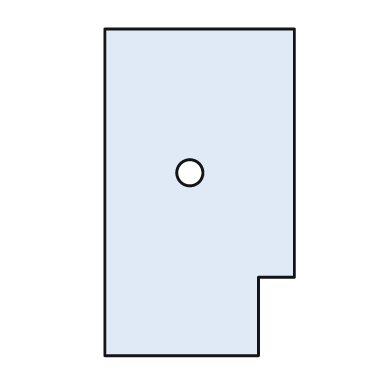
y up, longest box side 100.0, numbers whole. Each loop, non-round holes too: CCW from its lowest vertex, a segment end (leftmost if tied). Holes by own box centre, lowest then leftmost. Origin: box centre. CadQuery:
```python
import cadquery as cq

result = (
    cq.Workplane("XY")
    .moveTo(-29.0, -50.0)
    .lineTo(18.0, -50.0)
    .lineTo(18.0, -26.0)
    .lineTo(29.0, -26.0)
    .lineTo(29.0, 50.0)
    .lineTo(-29.0, 50.0)
    .close()
    .moveTo(-3.0, 6.0)
    .circle(4.0)
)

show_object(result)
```